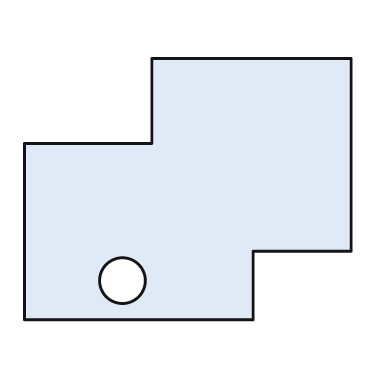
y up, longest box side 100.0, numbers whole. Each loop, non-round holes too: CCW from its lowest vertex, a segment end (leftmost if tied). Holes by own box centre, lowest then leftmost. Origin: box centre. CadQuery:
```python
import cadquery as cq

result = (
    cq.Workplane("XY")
    .moveTo(-50.0, -40.0)
    .lineTo(20.0, -40.0)
    .lineTo(20.0, -19.0)
    .lineTo(50.0, -19.0)
    .lineTo(50.0, 40.0)
    .lineTo(-11.0, 40.0)
    .lineTo(-11.0, 14.0)
    .lineTo(-50.0, 14.0)
    .close()
    .moveTo(-20.0, -28.0)
    .circle(7.0)
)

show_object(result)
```